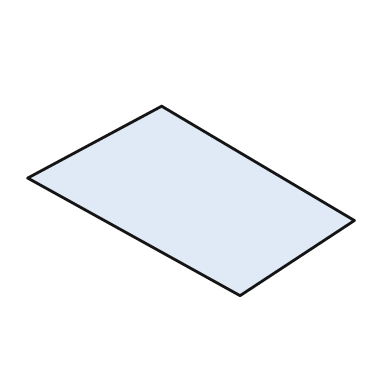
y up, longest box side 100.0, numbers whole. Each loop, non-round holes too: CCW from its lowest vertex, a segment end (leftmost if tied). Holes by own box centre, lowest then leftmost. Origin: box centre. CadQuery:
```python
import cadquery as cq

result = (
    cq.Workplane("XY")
    .moveTo(15.0, -29.0)
    .lineTo(50.0, -6.0)
    .lineTo(-9.0, 29.0)
    .lineTo(-50.0, 7.0)
    .close()
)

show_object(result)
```